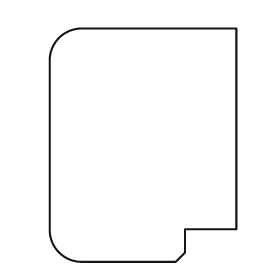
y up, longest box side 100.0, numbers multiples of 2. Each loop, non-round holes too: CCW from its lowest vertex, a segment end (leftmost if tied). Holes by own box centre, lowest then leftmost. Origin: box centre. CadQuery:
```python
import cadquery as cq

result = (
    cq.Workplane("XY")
    .moveTo(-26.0, -50.0)
    .lineTo(14.0, -50.0)
    .lineTo(18.0, -46.0)
    .lineTo(18.0, -36.0)
    .lineTo(40.0, -36.0)
    .lineTo(40.0, 50.0)
    .lineTo(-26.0, 50.0)
    .threePointArc((-36.0, 46.0), (-40.0, 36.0))
    .lineTo(-40.0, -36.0)
    .threePointArc((-36.0, -46.0), (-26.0, -50.0))
    .close()
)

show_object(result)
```